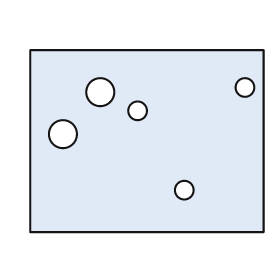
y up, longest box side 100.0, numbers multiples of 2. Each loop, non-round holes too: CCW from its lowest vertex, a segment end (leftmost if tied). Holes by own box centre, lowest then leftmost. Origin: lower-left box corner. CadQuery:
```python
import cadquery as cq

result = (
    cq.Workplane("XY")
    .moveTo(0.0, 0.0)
    .lineTo(100.0, 0.0)
    .lineTo(100.0, 78.0)
    .lineTo(0.0, 78.0)
    .close()
    .moveTo(66.0, 18.0)
    .circle(4.0)
    .moveTo(14.0, 42.0)
    .circle(6.0)
    .moveTo(46.0, 52.0)
    .circle(4.0)
    .moveTo(30.0, 60.0)
    .circle(6.0)
    .moveTo(92.0, 62.0)
    .circle(4.0)
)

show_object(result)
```